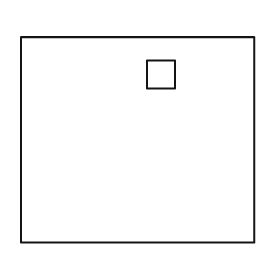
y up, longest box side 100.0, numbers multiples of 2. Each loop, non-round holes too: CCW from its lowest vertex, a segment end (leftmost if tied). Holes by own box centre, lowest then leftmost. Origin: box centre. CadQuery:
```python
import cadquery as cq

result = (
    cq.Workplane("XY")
    .moveTo(-50.0, -44.0)
    .lineTo(50.0, -44.0)
    .lineTo(50.0, 44.0)
    .lineTo(-50.0, 44.0)
    .close()
    .moveTo(4.0, 22.0)
    .lineTo(16.0, 22.0)
    .lineTo(16.0, 34.0)
    .lineTo(4.0, 34.0)
    .close()
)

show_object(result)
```